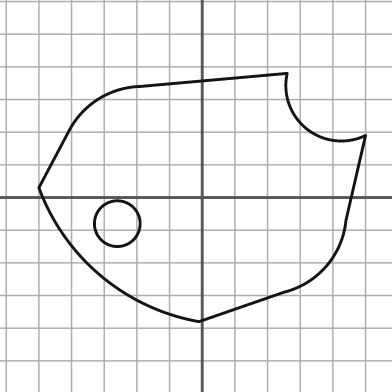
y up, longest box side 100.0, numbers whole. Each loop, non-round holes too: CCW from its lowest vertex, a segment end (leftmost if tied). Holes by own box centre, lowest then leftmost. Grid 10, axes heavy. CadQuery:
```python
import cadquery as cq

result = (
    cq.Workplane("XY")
    .moveTo(-1.0, -38.0)
    .lineTo(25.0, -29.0)
    .threePointArc((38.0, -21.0), (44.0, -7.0))
    .lineTo(50.0, 19.0)
    .threePointArc((32.0, 21.0), (26.0, 38.0))
    .lineTo(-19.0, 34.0)
    .threePointArc((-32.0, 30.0), (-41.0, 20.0))
    .lineTo(-50.0, 3.0)
    .threePointArc((-31.0, -24.0), (-1.0, -38.0))
    .close()
    .moveTo(-26.0, -8.0)
    .circle(7.0)
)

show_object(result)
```